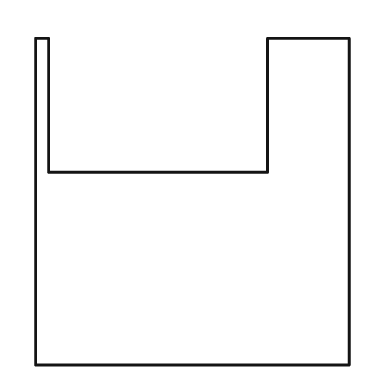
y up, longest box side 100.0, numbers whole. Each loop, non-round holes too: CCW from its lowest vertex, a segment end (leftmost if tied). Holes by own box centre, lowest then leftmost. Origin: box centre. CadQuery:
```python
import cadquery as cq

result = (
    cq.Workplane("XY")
    .moveTo(-48.0, -50.0)
    .lineTo(48.0, -50.0)
    .lineTo(48.0, 50.0)
    .lineTo(23.0, 50.0)
    .lineTo(23.0, 9.0)
    .lineTo(-44.0, 9.0)
    .lineTo(-44.0, 50.0)
    .lineTo(-48.0, 50.0)
    .close()
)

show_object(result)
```